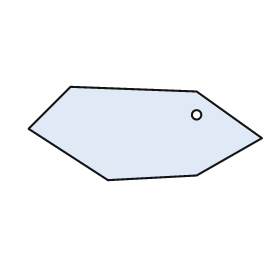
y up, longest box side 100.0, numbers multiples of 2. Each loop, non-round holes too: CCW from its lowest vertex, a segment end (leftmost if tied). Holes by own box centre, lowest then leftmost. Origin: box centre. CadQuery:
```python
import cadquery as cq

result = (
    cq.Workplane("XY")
    .moveTo(-16.0, -20.0)
    .lineTo(22.0, -18.0)
    .lineTo(50.0, -2.0)
    .lineTo(22.0, 18.0)
    .lineTo(-32.0, 20.0)
    .lineTo(-50.0, 2.0)
    .close()
    .moveTo(22.0, 8.0)
    .circle(2.0)
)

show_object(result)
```